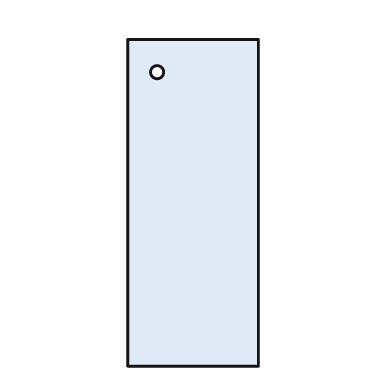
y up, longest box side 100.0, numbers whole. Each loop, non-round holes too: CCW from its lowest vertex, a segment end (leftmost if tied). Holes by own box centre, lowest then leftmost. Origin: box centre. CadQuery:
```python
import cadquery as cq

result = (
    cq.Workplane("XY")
    .moveTo(-20.0, -50.0)
    .lineTo(20.0, -50.0)
    .lineTo(20.0, 50.0)
    .lineTo(-20.0, 50.0)
    .close()
    .moveTo(-11.0, 40.0)
    .circle(2.0)
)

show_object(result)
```